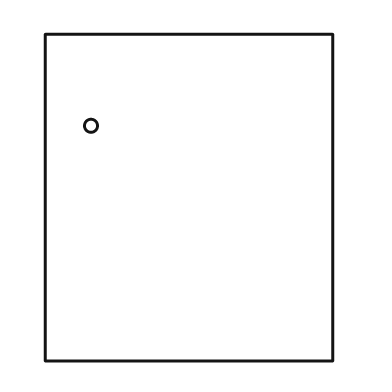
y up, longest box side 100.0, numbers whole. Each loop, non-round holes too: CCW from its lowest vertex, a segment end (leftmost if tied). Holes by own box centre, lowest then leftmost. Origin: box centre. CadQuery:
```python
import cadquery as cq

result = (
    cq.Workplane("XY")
    .moveTo(-44.0, -50.0)
    .lineTo(44.0, -50.0)
    .lineTo(44.0, 50.0)
    .lineTo(-44.0, 50.0)
    .close()
    .moveTo(-30.0, 22.0)
    .circle(2.0)
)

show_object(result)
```